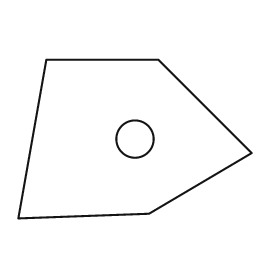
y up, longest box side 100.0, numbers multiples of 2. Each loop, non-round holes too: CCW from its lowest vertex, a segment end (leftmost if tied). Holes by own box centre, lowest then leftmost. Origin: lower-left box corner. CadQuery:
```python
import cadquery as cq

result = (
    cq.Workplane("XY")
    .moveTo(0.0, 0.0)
    .lineTo(56.0, 2.0)
    .lineTo(100.0, 28.0)
    .lineTo(60.0, 68.0)
    .lineTo(12.0, 68.0)
    .close()
    .moveTo(50.0, 34.0)
    .circle(8.0)
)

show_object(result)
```